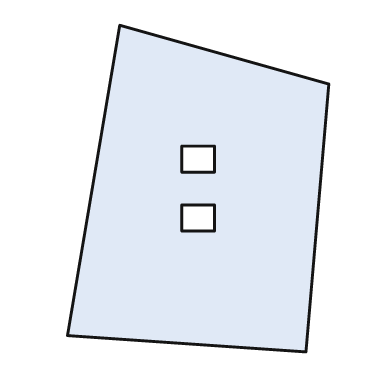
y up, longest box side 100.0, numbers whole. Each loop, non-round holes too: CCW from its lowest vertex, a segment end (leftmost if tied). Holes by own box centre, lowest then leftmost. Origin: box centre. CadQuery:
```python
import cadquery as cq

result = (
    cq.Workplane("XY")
    .moveTo(33.0, -50.0)
    .lineTo(40.0, 32.0)
    .lineTo(-24.0, 50.0)
    .lineTo(-40.0, -45.0)
    .close()
    .moveTo(-5.0, -13.0)
    .lineTo(5.0, -13.0)
    .lineTo(5.0, -5.0)
    .lineTo(-5.0, -5.0)
    .close()
    .moveTo(-5.0, 5.0)
    .lineTo(5.0, 5.0)
    .lineTo(5.0, 13.0)
    .lineTo(-5.0, 13.0)
    .close()
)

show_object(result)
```